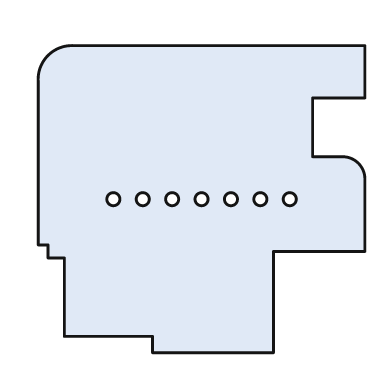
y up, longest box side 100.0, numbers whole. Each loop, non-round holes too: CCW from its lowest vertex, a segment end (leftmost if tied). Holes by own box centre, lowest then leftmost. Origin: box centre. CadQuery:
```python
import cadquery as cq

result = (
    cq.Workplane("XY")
    .moveTo(-15.0, -47.0)
    .lineTo(22.0, -47.0)
    .lineTo(22.0, -16.0)
    .lineTo(50.0, -16.0)
    .lineTo(50.0, 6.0)
    .threePointArc((48.0, 11.0), (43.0, 13.0))
    .lineTo(34.0, 13.0)
    .lineTo(34.0, 31.0)
    .lineTo(50.0, 31.0)
    .lineTo(50.0, 47.0)
    .lineTo(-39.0, 47.0)
    .threePointArc((-47.0, 44.0), (-50.0, 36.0))
    .lineTo(-50.0, -14.0)
    .lineTo(-47.0, -14.0)
    .lineTo(-47.0, -18.0)
    .lineTo(-42.0, -18.0)
    .lineTo(-42.0, -42.0)
    .lineTo(-15.0, -42.0)
    .close()
    .moveTo(-27.0, 0.0)
    .circle(2.0)
    .moveTo(-18.0, 0.0)
    .circle(2.0)
    .moveTo(-9.0, 0.0)
    .circle(2.0)
    .moveTo(0.0, 0.0)
    .circle(2.0)
    .moveTo(9.0, 0.0)
    .circle(2.0)
    .moveTo(18.0, 0.0)
    .circle(2.0)
    .moveTo(27.0, 0.0)
    .circle(2.0)
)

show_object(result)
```